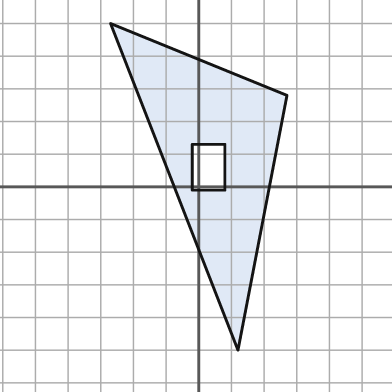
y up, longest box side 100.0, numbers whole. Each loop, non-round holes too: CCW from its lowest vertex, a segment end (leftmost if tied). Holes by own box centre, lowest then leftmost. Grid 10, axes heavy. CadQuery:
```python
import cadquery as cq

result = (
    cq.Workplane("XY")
    .moveTo(12.0, -50.0)
    .lineTo(27.0, 28.0)
    .lineTo(-27.0, 50.0)
    .close()
    .moveTo(-2.0, -1.0)
    .lineTo(8.0, -1.0)
    .lineTo(8.0, 13.0)
    .lineTo(-2.0, 13.0)
    .close()
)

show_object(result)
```